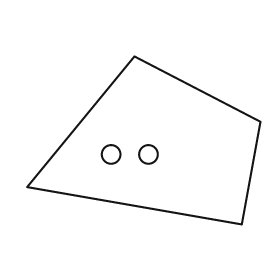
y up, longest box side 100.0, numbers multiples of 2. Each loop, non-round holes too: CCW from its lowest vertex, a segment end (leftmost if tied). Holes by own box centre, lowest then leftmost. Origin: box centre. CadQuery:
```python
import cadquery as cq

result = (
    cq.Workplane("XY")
    .moveTo(42.0, -36.0)
    .lineTo(50.0, 8.0)
    .lineTo(-4.0, 36.0)
    .lineTo(-50.0, -20.0)
    .close()
    .moveTo(-14.0, -6.0)
    .circle(4.0)
    .moveTo(2.0, -6.0)
    .circle(4.0)
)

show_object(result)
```